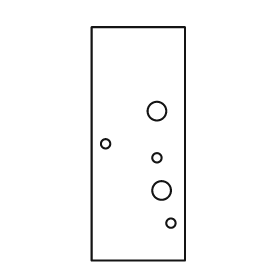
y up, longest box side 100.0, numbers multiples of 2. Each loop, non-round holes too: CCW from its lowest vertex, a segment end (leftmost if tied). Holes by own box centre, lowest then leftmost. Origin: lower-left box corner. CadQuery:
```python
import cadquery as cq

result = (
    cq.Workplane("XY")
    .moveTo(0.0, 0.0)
    .lineTo(40.0, 0.0)
    .lineTo(40.0, 100.0)
    .lineTo(0.0, 100.0)
    .close()
    .moveTo(34.0, 16.0)
    .circle(2.0)
    .moveTo(30.0, 30.0)
    .circle(4.0)
    .moveTo(28.0, 44.0)
    .circle(2.0)
    .moveTo(6.0, 50.0)
    .circle(2.0)
    .moveTo(28.0, 64.0)
    .circle(4.0)
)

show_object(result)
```